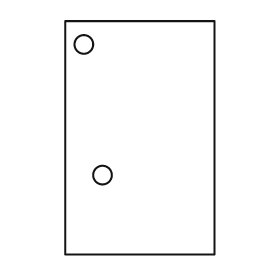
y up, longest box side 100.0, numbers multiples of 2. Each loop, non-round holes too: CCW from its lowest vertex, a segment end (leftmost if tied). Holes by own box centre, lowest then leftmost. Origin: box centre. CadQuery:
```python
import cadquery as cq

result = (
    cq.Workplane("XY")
    .moveTo(-32.0, -50.0)
    .lineTo(32.0, -50.0)
    .lineTo(32.0, 50.0)
    .lineTo(-32.0, 50.0)
    .close()
    .moveTo(-16.0, -16.0)
    .circle(4.0)
    .moveTo(-24.0, 40.0)
    .circle(4.0)
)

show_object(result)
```